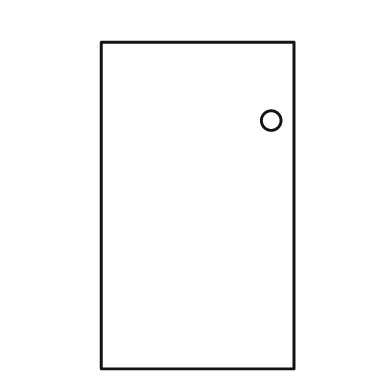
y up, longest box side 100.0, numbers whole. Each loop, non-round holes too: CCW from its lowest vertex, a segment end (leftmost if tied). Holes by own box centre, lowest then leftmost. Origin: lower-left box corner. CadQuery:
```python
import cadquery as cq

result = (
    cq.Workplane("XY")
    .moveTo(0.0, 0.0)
    .lineTo(59.0, 0.0)
    .lineTo(59.0, 100.0)
    .lineTo(0.0, 100.0)
    .close()
    .moveTo(52.0, 76.0)
    .circle(3.0)
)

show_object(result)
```